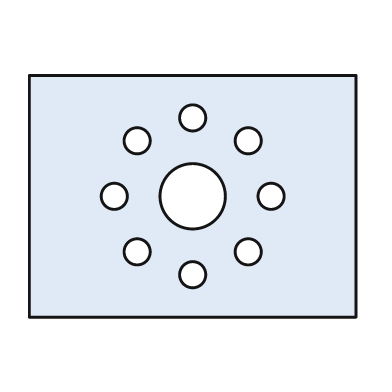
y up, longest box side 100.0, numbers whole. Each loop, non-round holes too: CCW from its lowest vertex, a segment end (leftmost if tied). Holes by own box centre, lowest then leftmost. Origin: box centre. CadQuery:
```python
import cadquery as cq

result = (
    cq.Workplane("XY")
    .moveTo(-50.0, -37.0)
    .lineTo(50.0, -37.0)
    .lineTo(50.0, 37.0)
    .lineTo(-50.0, 37.0)
    .close()
    .moveTo(0.0, -24.0)
    .circle(4.0)
    .moveTo(-17.0, -17.0)
    .circle(4.0)
    .moveTo(17.0, -17.0)
    .circle(4.0)
    .moveTo(-24.0, 0.0)
    .circle(4.0)
    .moveTo(0.0, 0.0)
    .circle(10.0)
    .moveTo(24.0, 0.0)
    .circle(4.0)
    .moveTo(-17.0, 17.0)
    .circle(4.0)
    .moveTo(17.0, 17.0)
    .circle(4.0)
    .moveTo(0.0, 24.0)
    .circle(4.0)
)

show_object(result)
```